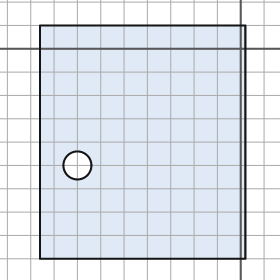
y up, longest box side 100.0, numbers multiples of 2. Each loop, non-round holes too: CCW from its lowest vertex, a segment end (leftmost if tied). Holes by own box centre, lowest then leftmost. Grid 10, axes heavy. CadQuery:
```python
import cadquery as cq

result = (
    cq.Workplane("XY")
    .moveTo(-86.0, -90.0)
    .lineTo(2.0, -90.0)
    .lineTo(2.0, 10.0)
    .lineTo(-86.0, 10.0)
    .close()
    .moveTo(-70.0, -50.0)
    .circle(6.0)
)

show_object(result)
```